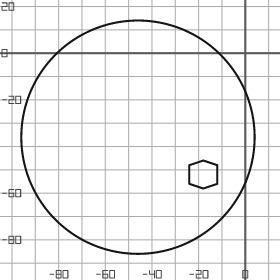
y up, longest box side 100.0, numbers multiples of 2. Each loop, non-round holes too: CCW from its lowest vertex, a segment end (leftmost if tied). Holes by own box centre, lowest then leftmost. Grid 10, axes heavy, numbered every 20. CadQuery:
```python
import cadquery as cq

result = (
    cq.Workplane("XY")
    .moveTo(-46.0, -36.0)
    .circle(50.0)
    .moveTo(-18.0, -58.0)
    .lineTo(-12.0, -56.0)
    .lineTo(-12.0, -48.0)
    .lineTo(-18.0, -46.0)
    .lineTo(-24.0, -48.0)
    .lineTo(-24.0, -56.0)
    .close()
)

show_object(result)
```